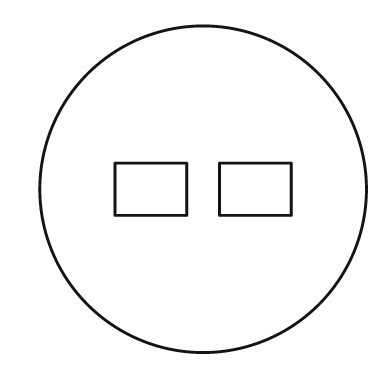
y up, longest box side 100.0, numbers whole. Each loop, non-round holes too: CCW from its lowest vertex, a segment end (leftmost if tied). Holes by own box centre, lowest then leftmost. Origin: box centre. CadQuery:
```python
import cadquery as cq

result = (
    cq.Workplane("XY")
    .moveTo(0.0, 0.0)
    .circle(50.0)
    .moveTo(-27.0, -8.0)
    .lineTo(-5.0, -8.0)
    .lineTo(-5.0, 8.0)
    .lineTo(-27.0, 8.0)
    .close()
    .moveTo(5.0, -8.0)
    .lineTo(27.0, -8.0)
    .lineTo(27.0, 8.0)
    .lineTo(5.0, 8.0)
    .close()
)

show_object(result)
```